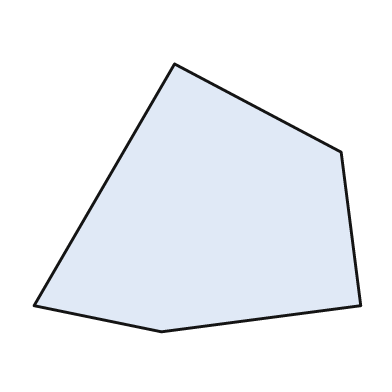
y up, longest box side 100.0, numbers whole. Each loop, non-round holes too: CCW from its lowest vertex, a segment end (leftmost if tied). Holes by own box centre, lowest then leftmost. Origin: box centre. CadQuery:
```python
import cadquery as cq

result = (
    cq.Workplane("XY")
    .moveTo(-11.0, -41.0)
    .lineTo(50.0, -33.0)
    .lineTo(44.0, 14.0)
    .lineTo(-7.0, 41.0)
    .lineTo(-50.0, -33.0)
    .close()
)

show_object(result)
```